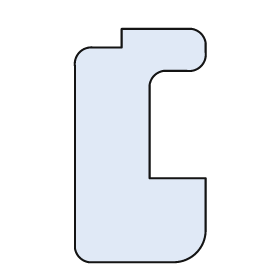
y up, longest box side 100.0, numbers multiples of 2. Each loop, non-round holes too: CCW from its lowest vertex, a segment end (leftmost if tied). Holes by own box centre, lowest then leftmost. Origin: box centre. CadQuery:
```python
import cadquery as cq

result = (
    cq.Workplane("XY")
    .moveTo(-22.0, -50.0)
    .lineTo(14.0, -50.0)
    .threePointArc((24.0, -46.0), (28.0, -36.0))
    .lineTo(28.0, -14.0)
    .lineTo(4.0, -14.0)
    .lineTo(4.0, 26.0)
    .threePointArc((6.0, 30.0), (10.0, 32.0))
    .lineTo(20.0, 32.0)
    .threePointArc((26.0, 34.0), (28.0, 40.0))
    .lineTo(28.0, 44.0)
    .threePointArc((26.0, 48.0), (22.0, 50.0))
    .lineTo(-8.0, 50.0)
    .lineTo(-8.0, 42.0)
    .lineTo(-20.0, 42.0)
    .threePointArc((-26.0, 40.0), (-28.0, 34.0))
    .lineTo(-28.0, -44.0)
    .threePointArc((-26.0, -48.0), (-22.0, -50.0))
    .close()
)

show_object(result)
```